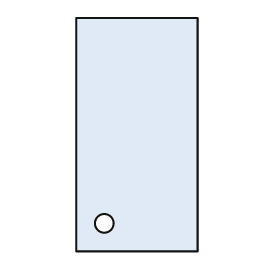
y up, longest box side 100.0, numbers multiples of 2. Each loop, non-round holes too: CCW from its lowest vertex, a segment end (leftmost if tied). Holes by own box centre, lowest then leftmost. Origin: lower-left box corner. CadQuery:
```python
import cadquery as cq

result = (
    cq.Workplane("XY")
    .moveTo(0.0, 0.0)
    .lineTo(52.0, 0.0)
    .lineTo(52.0, 100.0)
    .lineTo(0.0, 100.0)
    .close()
    .moveTo(12.0, 12.0)
    .circle(4.0)
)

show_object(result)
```